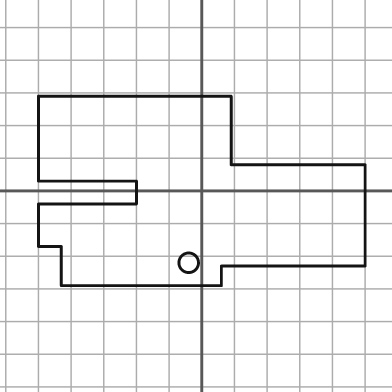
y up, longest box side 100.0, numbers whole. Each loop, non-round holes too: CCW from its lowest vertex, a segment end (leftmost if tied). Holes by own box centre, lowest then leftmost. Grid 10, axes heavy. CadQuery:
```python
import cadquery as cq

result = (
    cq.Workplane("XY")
    .moveTo(-43.0, -29.0)
    .lineTo(6.0, -29.0)
    .lineTo(6.0, -23.0)
    .lineTo(50.0, -23.0)
    .lineTo(50.0, 8.0)
    .lineTo(9.0, 8.0)
    .lineTo(9.0, 29.0)
    .lineTo(-50.0, 29.0)
    .lineTo(-50.0, 3.0)
    .lineTo(-20.0, 3.0)
    .lineTo(-20.0, -4.0)
    .lineTo(-50.0, -4.0)
    .lineTo(-50.0, -17.0)
    .lineTo(-43.0, -17.0)
    .close()
    .moveTo(-4.0, -22.0)
    .circle(3.0)
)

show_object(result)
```